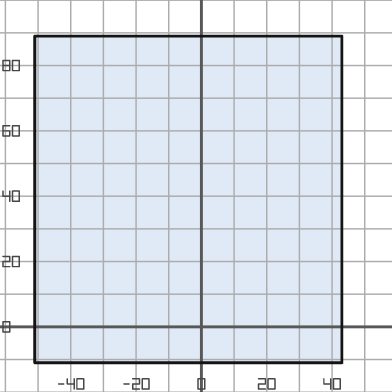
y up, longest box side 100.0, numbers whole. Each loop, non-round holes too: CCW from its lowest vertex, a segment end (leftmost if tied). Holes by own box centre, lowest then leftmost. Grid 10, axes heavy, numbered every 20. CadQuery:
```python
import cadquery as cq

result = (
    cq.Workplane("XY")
    .moveTo(-51.0, -11.0)
    .lineTo(43.0, -11.0)
    .lineTo(43.0, 89.0)
    .lineTo(-51.0, 89.0)
    .close()
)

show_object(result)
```